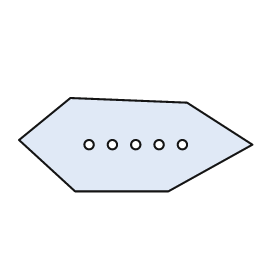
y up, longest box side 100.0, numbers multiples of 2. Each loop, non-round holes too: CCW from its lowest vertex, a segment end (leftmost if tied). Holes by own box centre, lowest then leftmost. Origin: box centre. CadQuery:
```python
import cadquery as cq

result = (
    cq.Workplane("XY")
    .moveTo(-26.0, -20.0)
    .lineTo(14.0, -20.0)
    .lineTo(50.0, 0.0)
    .lineTo(22.0, 18.0)
    .lineTo(-28.0, 20.0)
    .lineTo(-50.0, 2.0)
    .close()
    .moveTo(-20.0, 0.0)
    .circle(2.0)
    .moveTo(-10.0, 0.0)
    .circle(2.0)
    .moveTo(0.0, 0.0)
    .circle(2.0)
    .moveTo(10.0, 0.0)
    .circle(2.0)
    .moveTo(20.0, 0.0)
    .circle(2.0)
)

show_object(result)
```